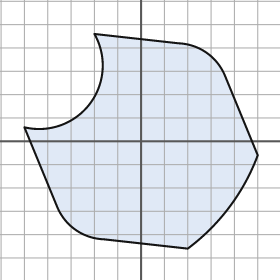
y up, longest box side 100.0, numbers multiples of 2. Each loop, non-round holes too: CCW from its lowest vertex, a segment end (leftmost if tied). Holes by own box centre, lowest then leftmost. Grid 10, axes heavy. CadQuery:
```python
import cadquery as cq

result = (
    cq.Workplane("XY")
    .moveTo(20.0, -46.0)
    .threePointArc((38.0, -28.0), (50.0, -6.0))
    .lineTo(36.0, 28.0)
    .threePointArc((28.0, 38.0), (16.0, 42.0))
    .lineTo(-20.0, 46.0)
    .threePointArc((-22.0, 16.0), (-50.0, 6.0))
    .lineTo(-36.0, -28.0)
    .threePointArc((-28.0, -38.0), (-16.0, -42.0))
    .close()
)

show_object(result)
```